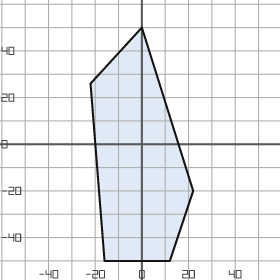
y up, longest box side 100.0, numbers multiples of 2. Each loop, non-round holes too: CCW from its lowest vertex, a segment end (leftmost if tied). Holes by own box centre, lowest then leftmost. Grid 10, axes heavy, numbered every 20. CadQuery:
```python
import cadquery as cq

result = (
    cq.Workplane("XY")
    .moveTo(-16.0, -50.0)
    .lineTo(12.0, -50.0)
    .lineTo(22.0, -20.0)
    .lineTo(0.0, 50.0)
    .lineTo(-22.0, 26.0)
    .close()
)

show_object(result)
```